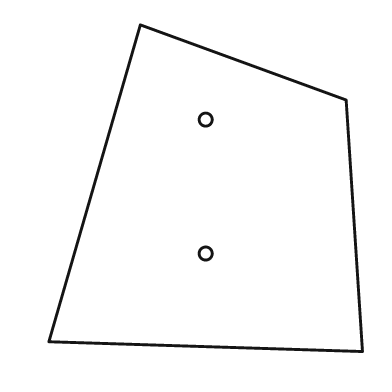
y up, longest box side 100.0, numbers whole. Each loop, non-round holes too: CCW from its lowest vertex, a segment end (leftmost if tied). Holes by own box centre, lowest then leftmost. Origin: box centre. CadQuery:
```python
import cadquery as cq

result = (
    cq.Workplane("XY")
    .moveTo(48.0, -50.0)
    .lineTo(43.0, 27.0)
    .lineTo(-20.0, 50.0)
    .lineTo(-48.0, -47.0)
    .close()
    .moveTo(0.0, -20.0)
    .circle(2.0)
    .moveTo(0.0, 21.0)
    .circle(2.0)
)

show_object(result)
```